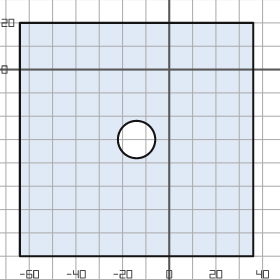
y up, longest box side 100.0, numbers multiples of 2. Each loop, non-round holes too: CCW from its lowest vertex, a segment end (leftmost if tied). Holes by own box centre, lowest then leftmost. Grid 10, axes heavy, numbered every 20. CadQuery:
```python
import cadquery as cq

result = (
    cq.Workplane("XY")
    .moveTo(-64.0, -80.0)
    .lineTo(36.0, -80.0)
    .lineTo(36.0, 20.0)
    .lineTo(-64.0, 20.0)
    .close()
    .moveTo(-14.0, -30.0)
    .circle(8.0)
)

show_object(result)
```